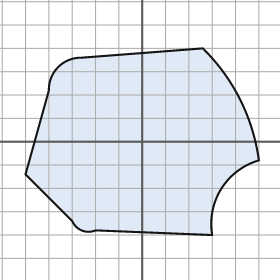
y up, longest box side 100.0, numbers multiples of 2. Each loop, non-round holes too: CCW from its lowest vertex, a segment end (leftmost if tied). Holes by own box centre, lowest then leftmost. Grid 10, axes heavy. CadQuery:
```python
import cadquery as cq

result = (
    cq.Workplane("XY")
    .moveTo(30.0, -40.0)
    .threePointArc((34.0, -20.0), (50.0, -8.0))
    .threePointArc((42.0, 18.0), (26.0, 40.0))
    .lineTo(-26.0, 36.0)
    .threePointArc((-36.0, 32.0), (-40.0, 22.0))
    .lineTo(-50.0, -14.0)
    .lineTo(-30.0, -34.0)
    .threePointArc((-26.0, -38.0), (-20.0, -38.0))
    .close()
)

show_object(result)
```